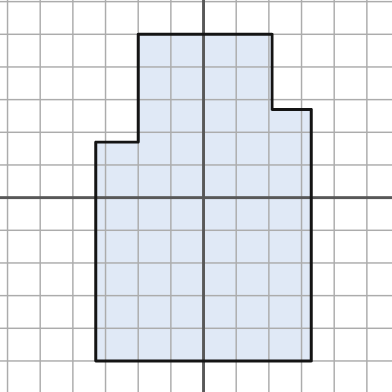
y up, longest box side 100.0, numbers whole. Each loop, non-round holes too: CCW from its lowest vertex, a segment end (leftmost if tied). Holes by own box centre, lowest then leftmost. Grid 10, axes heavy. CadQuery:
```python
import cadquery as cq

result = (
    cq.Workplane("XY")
    .moveTo(-33.0, -50.0)
    .lineTo(33.0, -50.0)
    .lineTo(33.0, 27.0)
    .lineTo(21.0, 27.0)
    .lineTo(21.0, 50.0)
    .lineTo(-20.0, 50.0)
    .lineTo(-20.0, 17.0)
    .lineTo(-33.0, 17.0)
    .close()
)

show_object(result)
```